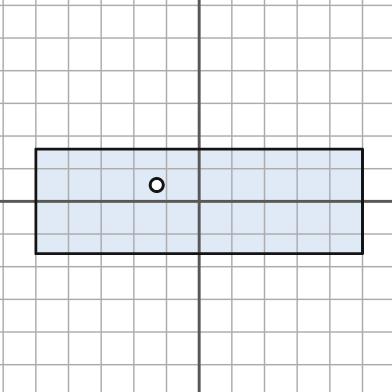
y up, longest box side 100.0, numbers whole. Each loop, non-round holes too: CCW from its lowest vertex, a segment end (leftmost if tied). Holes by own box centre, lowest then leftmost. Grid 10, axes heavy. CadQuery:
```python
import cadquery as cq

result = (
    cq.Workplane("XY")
    .moveTo(-50.0, -16.0)
    .lineTo(50.0, -16.0)
    .lineTo(50.0, 16.0)
    .lineTo(-50.0, 16.0)
    .close()
    .moveTo(-13.0, 5.0)
    .circle(2.0)
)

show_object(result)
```